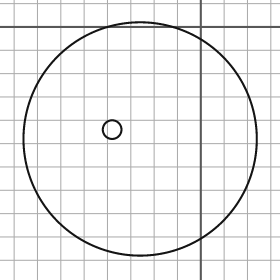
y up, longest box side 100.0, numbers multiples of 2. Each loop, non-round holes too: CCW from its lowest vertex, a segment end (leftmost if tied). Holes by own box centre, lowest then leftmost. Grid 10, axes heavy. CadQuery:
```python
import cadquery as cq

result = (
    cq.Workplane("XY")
    .moveTo(-26.0, -48.0)
    .circle(50.0)
    .moveTo(-38.0, -44.0)
    .circle(4.0)
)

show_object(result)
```